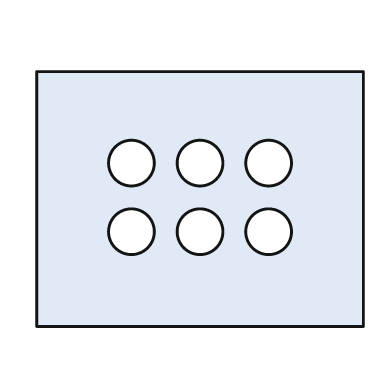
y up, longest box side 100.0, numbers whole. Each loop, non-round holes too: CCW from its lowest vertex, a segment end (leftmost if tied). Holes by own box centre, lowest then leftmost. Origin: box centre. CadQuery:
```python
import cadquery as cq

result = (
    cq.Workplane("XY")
    .moveTo(-50.0, -39.0)
    .lineTo(50.0, -39.0)
    .lineTo(50.0, 39.0)
    .lineTo(-50.0, 39.0)
    .close()
    .moveTo(-21.0, -10.0)
    .circle(7.0)
    .moveTo(0.0, -10.0)
    .circle(7.0)
    .moveTo(21.0, -10.0)
    .circle(7.0)
    .moveTo(-21.0, 11.0)
    .circle(7.0)
    .moveTo(0.0, 11.0)
    .circle(7.0)
    .moveTo(21.0, 11.0)
    .circle(7.0)
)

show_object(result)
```